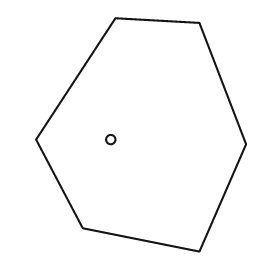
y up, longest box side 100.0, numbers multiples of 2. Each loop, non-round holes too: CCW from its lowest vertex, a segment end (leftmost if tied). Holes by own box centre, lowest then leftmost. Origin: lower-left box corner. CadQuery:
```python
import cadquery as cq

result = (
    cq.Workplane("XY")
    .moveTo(70.0, 0.0)
    .lineTo(90.0, 46.0)
    .lineTo(70.0, 98.0)
    .lineTo(34.0, 100.0)
    .lineTo(0.0, 48.0)
    .lineTo(20.0, 10.0)
    .close()
    .moveTo(32.0, 48.0)
    .circle(2.0)
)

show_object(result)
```